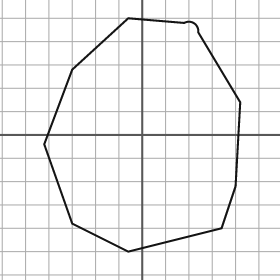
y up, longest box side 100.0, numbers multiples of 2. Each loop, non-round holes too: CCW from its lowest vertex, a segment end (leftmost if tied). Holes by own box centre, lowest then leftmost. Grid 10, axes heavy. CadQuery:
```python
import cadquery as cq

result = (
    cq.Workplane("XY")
    .moveTo(-6.0, -50.0)
    .lineTo(34.0, -40.0)
    .lineTo(40.0, -22.0)
    .lineTo(42.0, 14.0)
    .lineTo(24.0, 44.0)
    .threePointArc((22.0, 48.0), (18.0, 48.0))
    .lineTo(-6.0, 50.0)
    .lineTo(-30.0, 28.0)
    .lineTo(-42.0, -4.0)
    .lineTo(-30.0, -38.0)
    .close()
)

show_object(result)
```